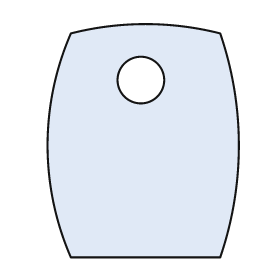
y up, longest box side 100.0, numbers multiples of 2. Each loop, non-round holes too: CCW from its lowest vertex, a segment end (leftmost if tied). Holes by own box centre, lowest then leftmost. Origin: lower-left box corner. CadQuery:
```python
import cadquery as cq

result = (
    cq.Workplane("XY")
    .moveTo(10.0, 0.0)
    .lineTo(74.0, 0.0)
    .threePointArc((82.0, 48.0), (74.0, 96.0))
    .threePointArc((42.0, 100.0), (10.0, 96.0))
    .threePointArc((0.0, 48.0), (10.0, 0.0))
    .close()
    .moveTo(40.0, 76.0)
    .circle(10.0)
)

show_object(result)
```